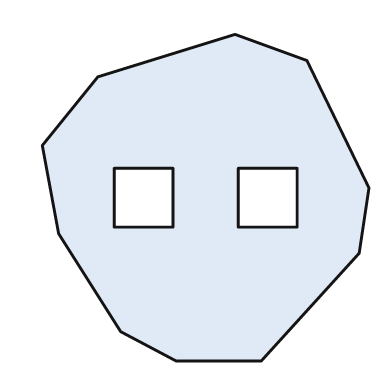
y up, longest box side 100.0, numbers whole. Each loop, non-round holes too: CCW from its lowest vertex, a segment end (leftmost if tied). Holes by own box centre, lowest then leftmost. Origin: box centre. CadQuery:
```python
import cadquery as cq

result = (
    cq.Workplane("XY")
    .moveTo(-9.0, -50.0)
    .lineTo(17.0, -50.0)
    .lineTo(47.0, -17.0)
    .lineTo(50.0, 3.0)
    .lineTo(31.0, 42.0)
    .lineTo(9.0, 50.0)
    .lineTo(-33.0, 37.0)
    .lineTo(-50.0, 16.0)
    .lineTo(-45.0, -11.0)
    .lineTo(-26.0, -41.0)
    .close()
    .moveTo(-28.0, -9.0)
    .lineTo(-10.0, -9.0)
    .lineTo(-10.0, 9.0)
    .lineTo(-28.0, 9.0)
    .close()
    .moveTo(10.0, -9.0)
    .lineTo(28.0, -9.0)
    .lineTo(28.0, 9.0)
    .lineTo(10.0, 9.0)
    .close()
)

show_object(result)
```